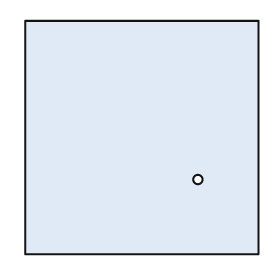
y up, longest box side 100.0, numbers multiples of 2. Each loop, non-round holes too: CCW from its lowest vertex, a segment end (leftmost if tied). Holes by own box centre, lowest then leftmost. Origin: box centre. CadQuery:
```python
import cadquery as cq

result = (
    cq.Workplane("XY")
    .moveTo(-50.0, -50.0)
    .lineTo(50.0, -50.0)
    .lineTo(50.0, 50.0)
    .lineTo(-50.0, 50.0)
    .close()
    .moveTo(24.0, -18.0)
    .circle(2.0)
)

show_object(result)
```